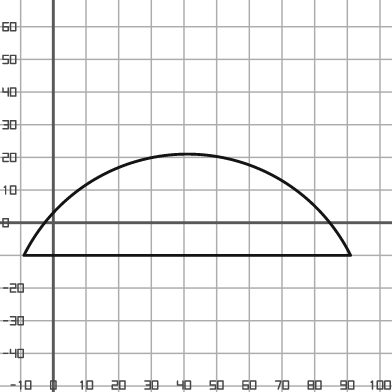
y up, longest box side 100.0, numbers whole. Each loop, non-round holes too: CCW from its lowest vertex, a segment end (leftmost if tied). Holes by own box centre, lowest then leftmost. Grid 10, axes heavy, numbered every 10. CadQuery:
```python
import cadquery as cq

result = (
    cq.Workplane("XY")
    .moveTo(-9.0, -10.0)
    .lineTo(91.0, -10.0)
    .threePointArc((41.0, 21.0), (-9.0, -10.0))
    .close()
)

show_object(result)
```